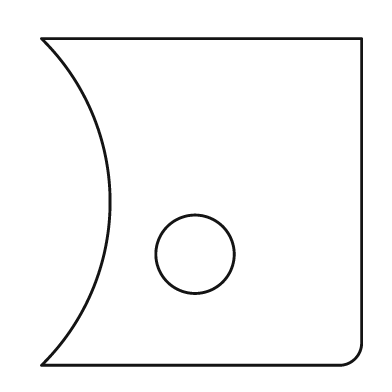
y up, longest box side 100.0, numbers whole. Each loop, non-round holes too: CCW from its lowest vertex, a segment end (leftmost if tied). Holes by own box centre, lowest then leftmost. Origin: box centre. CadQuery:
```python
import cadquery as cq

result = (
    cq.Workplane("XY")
    .moveTo(-49.0, -50.0)
    .lineTo(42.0, -50.0)
    .threePointArc((47.0, -48.0), (49.0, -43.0))
    .lineTo(49.0, 50.0)
    .lineTo(-49.0, 50.0)
    .threePointArc((-28.0, 0.0), (-49.0, -50.0))
    .close()
    .moveTo(-2.0, -16.0)
    .circle(12.0)
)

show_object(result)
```